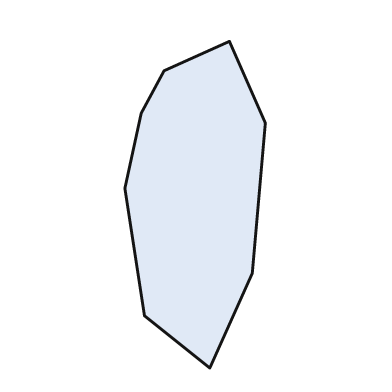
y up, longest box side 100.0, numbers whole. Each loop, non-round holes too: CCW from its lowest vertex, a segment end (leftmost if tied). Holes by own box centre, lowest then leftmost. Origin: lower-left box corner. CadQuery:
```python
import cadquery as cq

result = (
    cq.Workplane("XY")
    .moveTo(26.0, 0.0)
    .lineTo(39.0, 29.0)
    .lineTo(43.0, 75.0)
    .lineTo(32.0, 100.0)
    .lineTo(12.0, 91.0)
    .lineTo(5.0, 78.0)
    .lineTo(0.0, 55.0)
    .lineTo(6.0, 16.0)
    .close()
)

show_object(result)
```